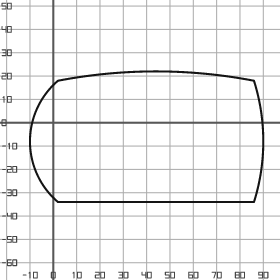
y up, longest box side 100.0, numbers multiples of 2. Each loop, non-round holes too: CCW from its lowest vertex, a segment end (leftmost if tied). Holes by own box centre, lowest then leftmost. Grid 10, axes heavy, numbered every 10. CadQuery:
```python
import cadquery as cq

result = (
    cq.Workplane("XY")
    .moveTo(2.0, -34.0)
    .lineTo(86.0, -34.0)
    .threePointArc((90.0, -8.0), (86.0, 18.0))
    .threePointArc((44.0, 22.0), (2.0, 18.0))
    .threePointArc((-10.0, -8.0), (2.0, -34.0))
    .close()
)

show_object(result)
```